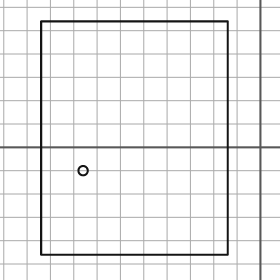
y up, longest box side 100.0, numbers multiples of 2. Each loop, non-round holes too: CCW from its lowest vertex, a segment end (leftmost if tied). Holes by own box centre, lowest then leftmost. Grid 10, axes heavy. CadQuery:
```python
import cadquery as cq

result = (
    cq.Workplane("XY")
    .moveTo(-94.0, -46.0)
    .lineTo(-14.0, -46.0)
    .lineTo(-14.0, 54.0)
    .lineTo(-94.0, 54.0)
    .close()
    .moveTo(-76.0, -10.0)
    .circle(2.0)
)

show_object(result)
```